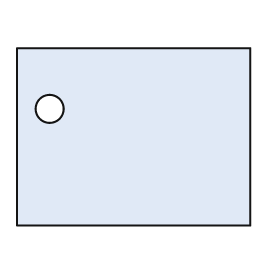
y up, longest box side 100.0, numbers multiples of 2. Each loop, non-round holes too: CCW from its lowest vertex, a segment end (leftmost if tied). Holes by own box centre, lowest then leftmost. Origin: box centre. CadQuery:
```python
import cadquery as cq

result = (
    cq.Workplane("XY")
    .moveTo(-50.0, -38.0)
    .lineTo(50.0, -38.0)
    .lineTo(50.0, 38.0)
    .lineTo(-50.0, 38.0)
    .close()
    .moveTo(-36.0, 12.0)
    .circle(6.0)
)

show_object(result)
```